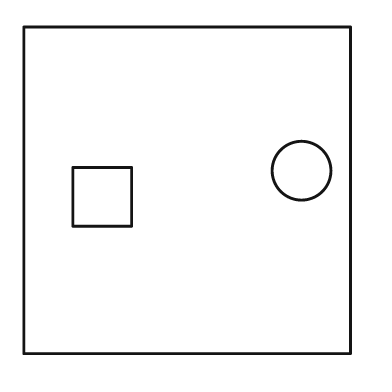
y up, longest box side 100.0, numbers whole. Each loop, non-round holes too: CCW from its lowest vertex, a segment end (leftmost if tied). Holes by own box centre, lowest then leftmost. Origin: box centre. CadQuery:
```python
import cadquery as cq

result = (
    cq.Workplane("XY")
    .moveTo(-50.0, -50.0)
    .lineTo(50.0, -50.0)
    .lineTo(50.0, 50.0)
    .lineTo(-50.0, 50.0)
    .close()
    .moveTo(-35.0, -11.0)
    .lineTo(-17.0, -11.0)
    .lineTo(-17.0, 7.0)
    .lineTo(-35.0, 7.0)
    .close()
    .moveTo(35.0, 6.0)
    .circle(9.0)
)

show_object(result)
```